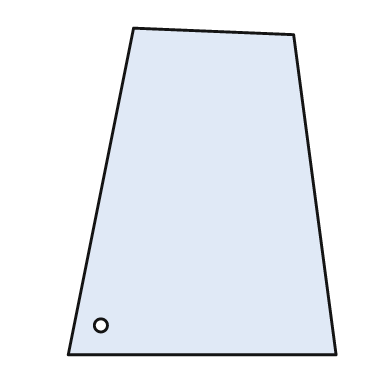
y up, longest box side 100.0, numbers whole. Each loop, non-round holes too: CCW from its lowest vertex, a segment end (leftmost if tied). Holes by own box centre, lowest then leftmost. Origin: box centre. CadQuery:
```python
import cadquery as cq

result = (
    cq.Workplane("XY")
    .moveTo(-41.0, -50.0)
    .lineTo(41.0, -50.0)
    .lineTo(28.0, 48.0)
    .lineTo(-21.0, 50.0)
    .close()
    .moveTo(-31.0, -41.0)
    .circle(2.0)
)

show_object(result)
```